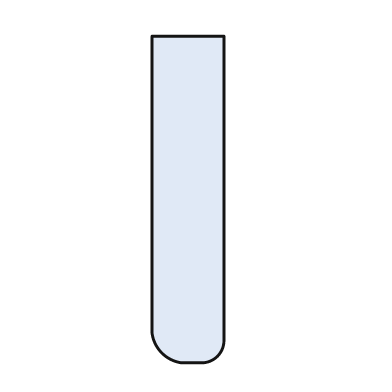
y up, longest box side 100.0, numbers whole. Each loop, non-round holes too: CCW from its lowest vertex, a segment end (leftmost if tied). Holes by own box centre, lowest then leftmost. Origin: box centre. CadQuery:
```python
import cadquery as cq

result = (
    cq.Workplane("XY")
    .moveTo(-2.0, -50.0)
    .lineTo(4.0, -50.0)
    .threePointArc((9.0, -48.0), (11.0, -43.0))
    .lineTo(11.0, 50.0)
    .lineTo(-11.0, 50.0)
    .lineTo(-11.0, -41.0)
    .threePointArc((-8.0, -47.0), (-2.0, -50.0))
    .close()
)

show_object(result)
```